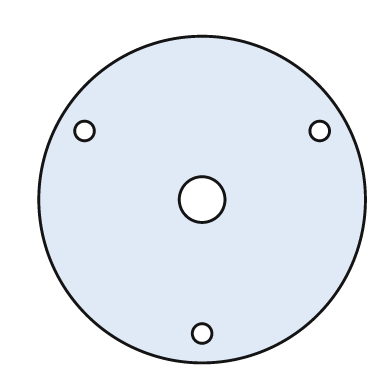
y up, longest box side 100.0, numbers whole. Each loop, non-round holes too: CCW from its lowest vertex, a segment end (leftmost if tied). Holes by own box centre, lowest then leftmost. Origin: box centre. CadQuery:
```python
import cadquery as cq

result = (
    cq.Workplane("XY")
    .moveTo(0.0, 0.0)
    .circle(50.0)
    .moveTo(0.0, -41.0)
    .circle(3.0)
    .moveTo(0.0, 0.0)
    .circle(7.0)
    .moveTo(-36.0, 21.0)
    .circle(3.0)
    .moveTo(36.0, 21.0)
    .circle(3.0)
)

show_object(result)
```